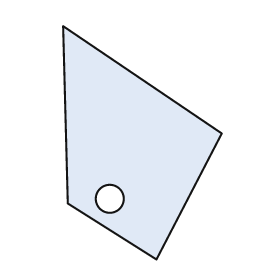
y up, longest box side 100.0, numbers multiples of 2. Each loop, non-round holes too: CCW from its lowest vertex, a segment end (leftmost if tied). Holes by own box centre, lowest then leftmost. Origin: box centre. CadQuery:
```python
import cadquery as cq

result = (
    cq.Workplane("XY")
    .moveTo(6.0, -50.0)
    .lineTo(34.0, 4.0)
    .lineTo(-34.0, 50.0)
    .lineTo(-32.0, -26.0)
    .close()
    .moveTo(-14.0, -24.0)
    .circle(6.0)
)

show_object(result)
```